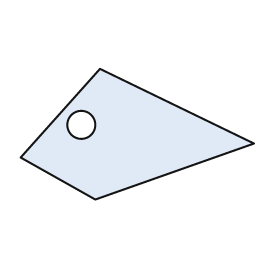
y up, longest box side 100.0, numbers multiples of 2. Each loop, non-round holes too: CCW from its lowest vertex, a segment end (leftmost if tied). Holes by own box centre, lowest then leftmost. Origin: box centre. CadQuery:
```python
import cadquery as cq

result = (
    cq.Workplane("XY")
    .moveTo(-18.0, -28.0)
    .lineTo(50.0, -4.0)
    .lineTo(-16.0, 28.0)
    .lineTo(-50.0, -10.0)
    .close()
    .moveTo(-24.0, 4.0)
    .circle(6.0)
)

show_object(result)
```